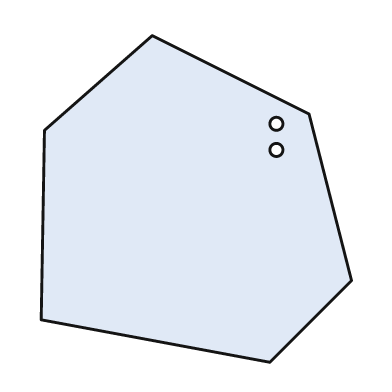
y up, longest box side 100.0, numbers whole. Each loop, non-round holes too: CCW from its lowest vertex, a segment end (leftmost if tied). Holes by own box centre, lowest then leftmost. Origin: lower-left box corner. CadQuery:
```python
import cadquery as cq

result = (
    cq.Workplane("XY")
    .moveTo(70.0, 0.0)
    .lineTo(95.0, 25.0)
    .lineTo(82.0, 76.0)
    .lineTo(34.0, 100.0)
    .lineTo(1.0, 71.0)
    .lineTo(0.0, 13.0)
    .close()
    .moveTo(72.0, 65.0)
    .circle(2.0)
    .moveTo(72.0, 73.0)
    .circle(2.0)
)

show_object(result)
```